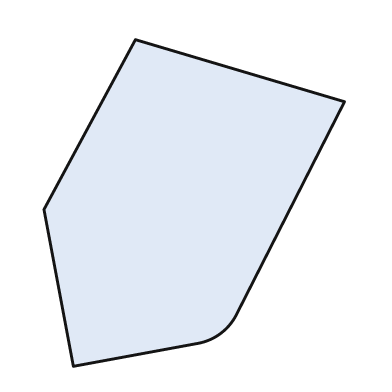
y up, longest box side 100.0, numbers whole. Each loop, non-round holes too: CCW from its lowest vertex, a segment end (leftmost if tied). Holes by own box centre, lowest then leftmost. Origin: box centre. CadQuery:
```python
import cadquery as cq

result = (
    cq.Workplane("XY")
    .moveTo(-37.0, -50.0)
    .lineTo(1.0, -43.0)
    .threePointArc((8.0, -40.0), (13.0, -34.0))
    .lineTo(46.0, 31.0)
    .lineTo(-18.0, 50.0)
    .lineTo(-46.0, -2.0)
    .close()
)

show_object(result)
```